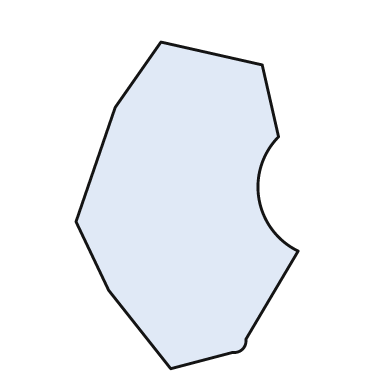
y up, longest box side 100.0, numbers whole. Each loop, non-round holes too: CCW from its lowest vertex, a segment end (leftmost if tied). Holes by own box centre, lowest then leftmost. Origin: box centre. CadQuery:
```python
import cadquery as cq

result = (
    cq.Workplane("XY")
    .moveTo(-5.0, -50.0)
    .lineTo(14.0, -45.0)
    .threePointArc((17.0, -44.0), (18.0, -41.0))
    .lineTo(34.0, -14.0)
    .threePointArc((22.0, 2.0), (28.0, 21.0))
    .lineTo(23.0, 43.0)
    .lineTo(-8.0, 50.0)
    .lineTo(-22.0, 30.0)
    .lineTo(-34.0, -5.0)
    .lineTo(-24.0, -26.0)
    .close()
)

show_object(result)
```